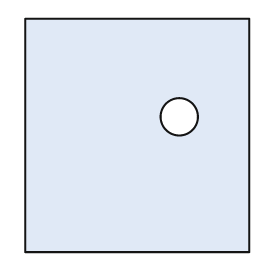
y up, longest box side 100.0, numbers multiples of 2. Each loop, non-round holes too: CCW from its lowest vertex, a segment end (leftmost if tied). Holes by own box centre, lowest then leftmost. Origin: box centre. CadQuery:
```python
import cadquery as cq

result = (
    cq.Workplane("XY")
    .moveTo(-48.0, -50.0)
    .lineTo(48.0, -50.0)
    .lineTo(48.0, 50.0)
    .lineTo(-48.0, 50.0)
    .close()
    .moveTo(18.0, 8.0)
    .circle(8.0)
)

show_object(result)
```